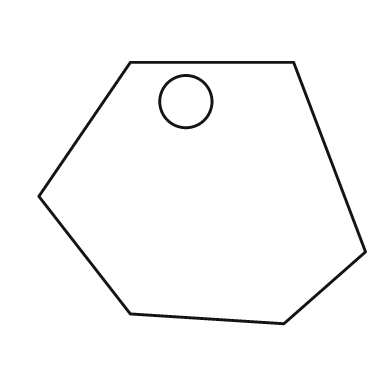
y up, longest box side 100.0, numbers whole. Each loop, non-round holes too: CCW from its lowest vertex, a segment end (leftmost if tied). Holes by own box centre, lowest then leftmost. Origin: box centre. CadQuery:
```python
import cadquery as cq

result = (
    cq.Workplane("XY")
    .moveTo(25.0, -40.0)
    .lineTo(50.0, -18.0)
    .lineTo(28.0, 40.0)
    .lineTo(-22.0, 40.0)
    .lineTo(-50.0, -1.0)
    .lineTo(-22.0, -37.0)
    .close()
    .moveTo(-5.0, 28.0)
    .circle(8.0)
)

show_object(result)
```